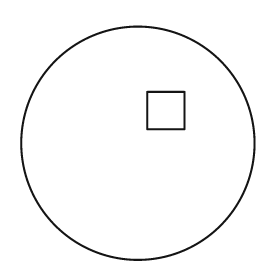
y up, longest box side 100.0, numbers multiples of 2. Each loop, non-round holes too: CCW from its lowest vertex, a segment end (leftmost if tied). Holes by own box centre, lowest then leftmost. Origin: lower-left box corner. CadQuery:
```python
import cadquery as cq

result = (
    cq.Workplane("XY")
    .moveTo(50.0, 50.0)
    .circle(50.0)
    .moveTo(54.0, 56.0)
    .lineTo(70.0, 56.0)
    .lineTo(70.0, 72.0)
    .lineTo(54.0, 72.0)
    .close()
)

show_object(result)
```